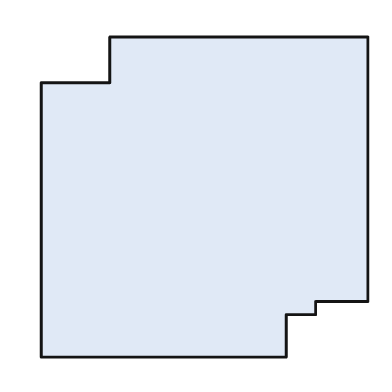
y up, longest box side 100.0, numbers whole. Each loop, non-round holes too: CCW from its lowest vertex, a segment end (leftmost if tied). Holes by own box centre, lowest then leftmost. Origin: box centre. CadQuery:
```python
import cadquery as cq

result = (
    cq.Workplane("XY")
    .moveTo(-50.0, -49.0)
    .lineTo(25.0, -49.0)
    .lineTo(25.0, -36.0)
    .lineTo(34.0, -36.0)
    .lineTo(34.0, -32.0)
    .lineTo(50.0, -32.0)
    .lineTo(50.0, 49.0)
    .lineTo(-29.0, 49.0)
    .lineTo(-29.0, 35.0)
    .lineTo(-50.0, 35.0)
    .close()
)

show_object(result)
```